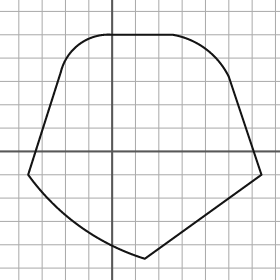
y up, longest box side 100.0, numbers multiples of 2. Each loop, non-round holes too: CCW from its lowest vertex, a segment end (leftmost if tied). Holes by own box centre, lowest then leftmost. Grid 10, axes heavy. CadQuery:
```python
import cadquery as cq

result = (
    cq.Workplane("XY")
    .moveTo(14.0, -46.0)
    .lineTo(64.0, -10.0)
    .lineTo(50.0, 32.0)
    .threePointArc((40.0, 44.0), (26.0, 50.0))
    .lineTo(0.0, 50.0)
    .threePointArc((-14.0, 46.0), (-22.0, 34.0))
    .lineTo(-36.0, -10.0)
    .threePointArc((-14.0, -32.0), (14.0, -46.0))
    .close()
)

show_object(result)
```